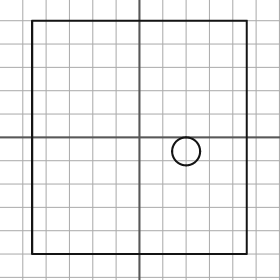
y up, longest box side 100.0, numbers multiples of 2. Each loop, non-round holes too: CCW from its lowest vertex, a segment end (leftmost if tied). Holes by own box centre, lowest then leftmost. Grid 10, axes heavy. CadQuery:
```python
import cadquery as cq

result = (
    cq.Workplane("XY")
    .moveTo(-46.0, -50.0)
    .lineTo(46.0, -50.0)
    .lineTo(46.0, 50.0)
    .lineTo(-46.0, 50.0)
    .close()
    .moveTo(20.0, -6.0)
    .circle(6.0)
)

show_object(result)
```